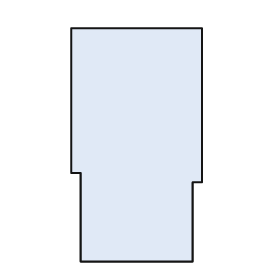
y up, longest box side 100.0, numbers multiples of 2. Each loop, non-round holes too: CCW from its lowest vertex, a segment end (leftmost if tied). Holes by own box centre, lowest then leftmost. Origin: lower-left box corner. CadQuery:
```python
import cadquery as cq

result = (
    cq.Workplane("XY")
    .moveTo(4.0, 0.0)
    .lineTo(52.0, 0.0)
    .lineTo(52.0, 34.0)
    .lineTo(56.0, 34.0)
    .lineTo(56.0, 100.0)
    .lineTo(0.0, 100.0)
    .lineTo(0.0, 38.0)
    .lineTo(4.0, 38.0)
    .close()
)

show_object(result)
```